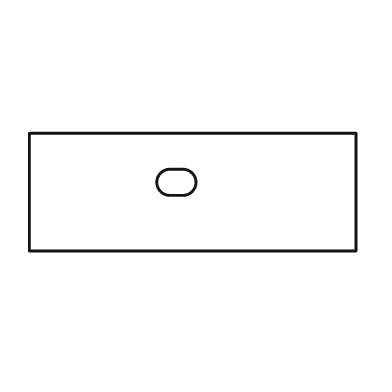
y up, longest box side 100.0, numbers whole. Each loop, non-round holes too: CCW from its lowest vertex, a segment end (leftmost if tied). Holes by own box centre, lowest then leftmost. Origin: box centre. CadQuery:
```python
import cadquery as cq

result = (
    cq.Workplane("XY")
    .moveTo(-50.0, -18.0)
    .lineTo(50.0, -18.0)
    .lineTo(50.0, 18.0)
    .lineTo(-50.0, 18.0)
    .close()
    .moveTo(-7.0, -1.0)
    .lineTo(-3.0, -1.0)
    .threePointArc((1.0, 3.0), (-3.0, 7.0))
    .lineTo(-7.0, 7.0)
    .threePointArc((-11.0, 3.0), (-7.0, -1.0))
    .close()
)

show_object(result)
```